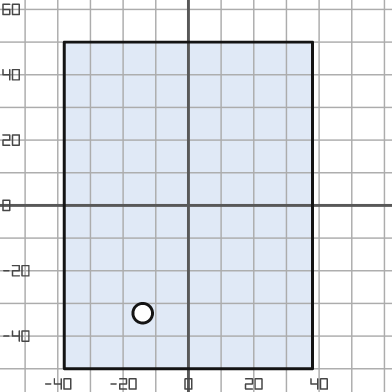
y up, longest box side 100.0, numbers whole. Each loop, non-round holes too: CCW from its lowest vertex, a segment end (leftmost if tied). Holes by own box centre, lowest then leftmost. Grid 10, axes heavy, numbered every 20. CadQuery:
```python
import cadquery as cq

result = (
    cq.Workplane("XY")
    .moveTo(-38.0, -50.0)
    .lineTo(38.0, -50.0)
    .lineTo(38.0, 50.0)
    .lineTo(-38.0, 50.0)
    .close()
    .moveTo(-14.0, -33.0)
    .circle(3.0)
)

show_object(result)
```